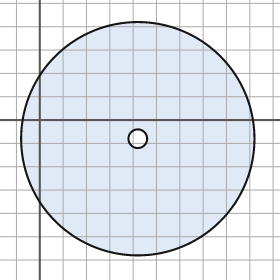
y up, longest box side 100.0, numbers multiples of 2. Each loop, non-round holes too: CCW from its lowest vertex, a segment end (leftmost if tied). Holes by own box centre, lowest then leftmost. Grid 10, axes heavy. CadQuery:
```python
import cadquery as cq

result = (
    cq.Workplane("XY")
    .moveTo(42.0, -8.0)
    .circle(50.0)
    .moveTo(42.0, -8.0)
    .circle(4.0)
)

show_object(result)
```